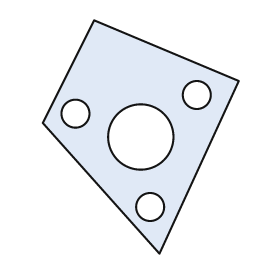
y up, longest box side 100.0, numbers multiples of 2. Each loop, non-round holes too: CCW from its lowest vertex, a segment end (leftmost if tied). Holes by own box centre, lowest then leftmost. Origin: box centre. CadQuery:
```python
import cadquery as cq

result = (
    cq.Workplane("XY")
    .moveTo(8.0, -50.0)
    .lineTo(42.0, 24.0)
    .lineTo(-20.0, 50.0)
    .lineTo(-42.0, 6.0)
    .close()
    .moveTo(4.0, -30.0)
    .circle(6.0)
    .moveTo(0.0, 0.0)
    .circle(14.0)
    .moveTo(-28.0, 10.0)
    .circle(6.0)
    .moveTo(24.0, 18.0)
    .circle(6.0)
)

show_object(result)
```